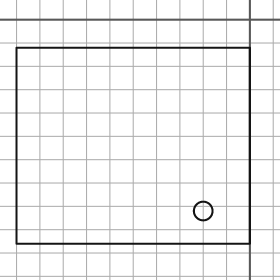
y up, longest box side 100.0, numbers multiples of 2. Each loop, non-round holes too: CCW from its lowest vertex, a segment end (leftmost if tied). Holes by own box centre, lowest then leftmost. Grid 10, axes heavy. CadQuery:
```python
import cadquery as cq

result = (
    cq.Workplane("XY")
    .moveTo(-100.0, -96.0)
    .lineTo(0.0, -96.0)
    .lineTo(0.0, -12.0)
    .lineTo(-100.0, -12.0)
    .close()
    .moveTo(-20.0, -82.0)
    .circle(4.0)
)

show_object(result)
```